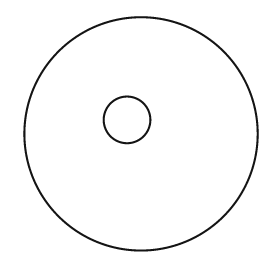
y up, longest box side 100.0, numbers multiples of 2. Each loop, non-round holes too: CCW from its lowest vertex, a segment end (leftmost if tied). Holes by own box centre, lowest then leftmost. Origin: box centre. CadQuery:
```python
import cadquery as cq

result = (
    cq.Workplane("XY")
    .moveTo(0.0, 0.0)
    .circle(50.0)
    .moveTo(-6.0, 6.0)
    .circle(10.0)
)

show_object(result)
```